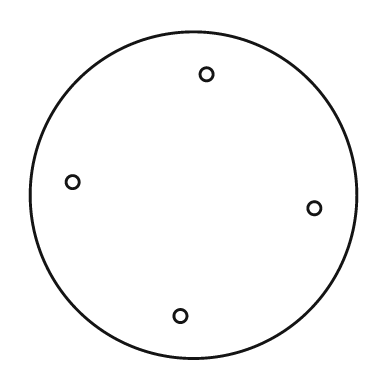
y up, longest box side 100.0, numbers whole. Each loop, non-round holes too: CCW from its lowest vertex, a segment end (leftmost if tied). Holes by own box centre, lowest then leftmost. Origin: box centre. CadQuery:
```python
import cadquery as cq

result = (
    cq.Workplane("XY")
    .moveTo(0.0, 0.0)
    .circle(50.0)
    .moveTo(-4.0, -37.0)
    .circle(2.0)
    .moveTo(37.0, -4.0)
    .circle(2.0)
    .moveTo(-37.0, 4.0)
    .circle(2.0)
    .moveTo(4.0, 37.0)
    .circle(2.0)
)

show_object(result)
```